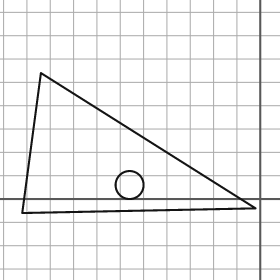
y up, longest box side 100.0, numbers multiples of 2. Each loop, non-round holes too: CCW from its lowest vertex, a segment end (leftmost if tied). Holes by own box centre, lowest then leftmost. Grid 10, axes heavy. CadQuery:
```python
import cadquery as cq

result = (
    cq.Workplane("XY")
    .moveTo(-102.0, -6.0)
    .lineTo(-2.0, -4.0)
    .lineTo(-94.0, 54.0)
    .close()
    .moveTo(-56.0, 6.0)
    .circle(6.0)
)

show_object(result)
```